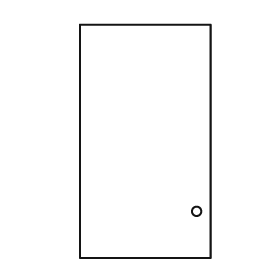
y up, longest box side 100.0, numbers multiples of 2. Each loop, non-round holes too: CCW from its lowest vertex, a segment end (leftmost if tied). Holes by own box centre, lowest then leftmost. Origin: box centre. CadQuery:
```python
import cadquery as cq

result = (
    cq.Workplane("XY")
    .moveTo(-28.0, -50.0)
    .lineTo(28.0, -50.0)
    .lineTo(28.0, 50.0)
    .lineTo(-28.0, 50.0)
    .close()
    .moveTo(22.0, -30.0)
    .circle(2.0)
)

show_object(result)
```